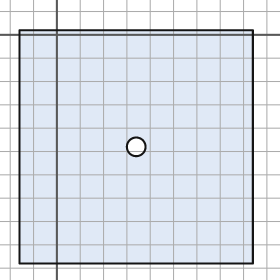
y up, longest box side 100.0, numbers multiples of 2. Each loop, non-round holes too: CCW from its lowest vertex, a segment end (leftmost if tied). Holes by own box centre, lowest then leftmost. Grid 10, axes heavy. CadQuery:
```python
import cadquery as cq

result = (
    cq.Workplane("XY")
    .moveTo(-16.0, -98.0)
    .lineTo(84.0, -98.0)
    .lineTo(84.0, 2.0)
    .lineTo(-16.0, 2.0)
    .close()
    .moveTo(34.0, -48.0)
    .circle(4.0)
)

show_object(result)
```